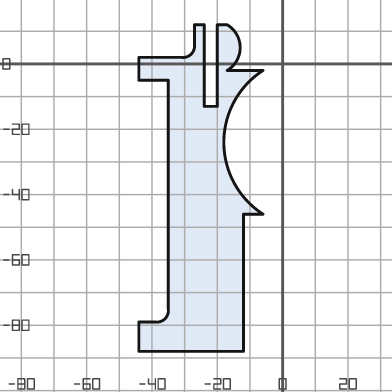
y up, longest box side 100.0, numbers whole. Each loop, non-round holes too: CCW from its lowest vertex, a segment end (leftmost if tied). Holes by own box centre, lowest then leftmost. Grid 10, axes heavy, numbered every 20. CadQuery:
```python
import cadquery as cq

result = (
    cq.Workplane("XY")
    .moveTo(-44.0, -88.0)
    .lineTo(-12.0, -88.0)
    .lineTo(-12.0, -46.0)
    .lineTo(-6.0, -46.0)
    .threePointArc((-18.0, -24.0), (-6.0, -2.0))
    .lineTo(-17.0, -2.0)
    .threePointArc((-13.0, 5.0), (-17.0, 12.0))
    .lineTo(-20.0, 12.0)
    .lineTo(-20.0, -13.0)
    .lineTo(-24.0, -13.0)
    .lineTo(-24.0, 12.0)
    .lineTo(-27.0, 12.0)
    .lineTo(-27.0, 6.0)
    .threePointArc((-28.0, 3.0), (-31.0, 2.0))
    .lineTo(-44.0, 2.0)
    .lineTo(-44.0, -5.0)
    .lineTo(-35.0, -5.0)
    .lineTo(-35.0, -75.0)
    .threePointArc((-36.0, -78.0), (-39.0, -79.0))
    .lineTo(-44.0, -79.0)
    .close()
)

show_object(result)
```